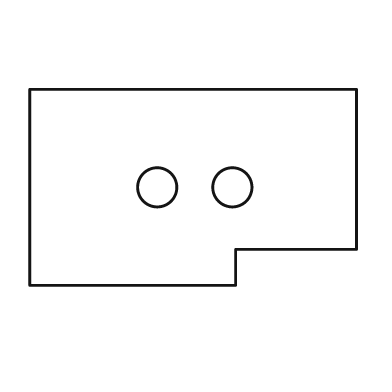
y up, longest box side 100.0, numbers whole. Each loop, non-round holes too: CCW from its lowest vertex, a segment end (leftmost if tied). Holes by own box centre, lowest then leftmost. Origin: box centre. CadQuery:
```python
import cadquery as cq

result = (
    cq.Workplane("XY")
    .moveTo(-50.0, -30.0)
    .lineTo(13.0, -30.0)
    .lineTo(13.0, -19.0)
    .lineTo(50.0, -19.0)
    .lineTo(50.0, 30.0)
    .lineTo(-50.0, 30.0)
    .close()
    .moveTo(-11.0, 0.0)
    .circle(6.0)
    .moveTo(12.0, 0.0)
    .circle(6.0)
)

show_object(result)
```